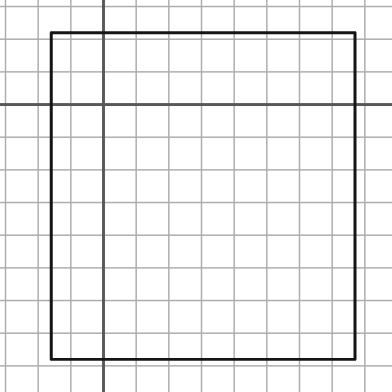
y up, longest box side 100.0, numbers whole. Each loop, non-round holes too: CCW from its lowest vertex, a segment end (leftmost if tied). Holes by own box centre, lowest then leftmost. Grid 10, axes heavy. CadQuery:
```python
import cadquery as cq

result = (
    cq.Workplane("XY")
    .moveTo(-16.0, -78.0)
    .lineTo(77.0, -78.0)
    .lineTo(77.0, 22.0)
    .lineTo(-16.0, 22.0)
    .close()
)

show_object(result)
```